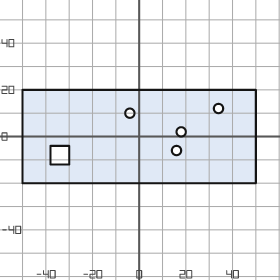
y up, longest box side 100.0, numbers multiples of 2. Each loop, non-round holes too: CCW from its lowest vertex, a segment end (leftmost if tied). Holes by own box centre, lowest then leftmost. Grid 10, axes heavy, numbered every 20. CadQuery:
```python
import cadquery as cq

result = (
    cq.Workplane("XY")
    .moveTo(-50.0, -20.0)
    .lineTo(50.0, -20.0)
    .lineTo(50.0, 20.0)
    .lineTo(-50.0, 20.0)
    .close()
    .moveTo(-38.0, -12.0)
    .lineTo(-30.0, -12.0)
    .lineTo(-30.0, -4.0)
    .lineTo(-38.0, -4.0)
    .close()
    .moveTo(16.0, -6.0)
    .circle(2.0)
    .moveTo(18.0, 2.0)
    .circle(2.0)
    .moveTo(-4.0, 10.0)
    .circle(2.0)
    .moveTo(34.0, 12.0)
    .circle(2.0)
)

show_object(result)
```